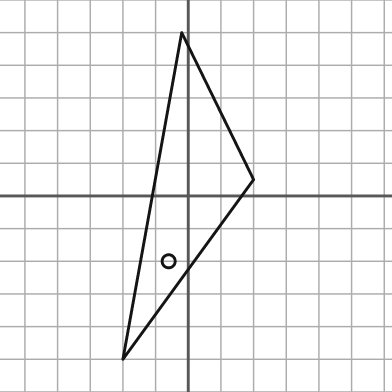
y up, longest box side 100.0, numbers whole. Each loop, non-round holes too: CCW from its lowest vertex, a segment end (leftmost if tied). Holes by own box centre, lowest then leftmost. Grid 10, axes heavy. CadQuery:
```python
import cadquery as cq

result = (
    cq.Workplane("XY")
    .moveTo(-20.0, -50.0)
    .lineTo(20.0, 5.0)
    .lineTo(-2.0, 50.0)
    .close()
    .moveTo(-6.0, -20.0)
    .circle(2.0)
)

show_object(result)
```